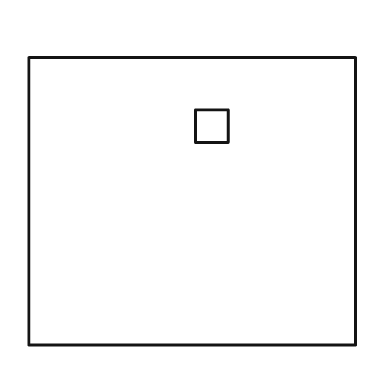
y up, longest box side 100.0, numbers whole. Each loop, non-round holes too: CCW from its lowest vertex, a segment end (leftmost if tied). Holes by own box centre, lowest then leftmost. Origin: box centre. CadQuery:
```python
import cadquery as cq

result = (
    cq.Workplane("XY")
    .moveTo(-50.0, -44.0)
    .lineTo(50.0, -44.0)
    .lineTo(50.0, 44.0)
    .lineTo(-50.0, 44.0)
    .close()
    .moveTo(1.0, 18.0)
    .lineTo(11.0, 18.0)
    .lineTo(11.0, 28.0)
    .lineTo(1.0, 28.0)
    .close()
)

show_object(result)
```